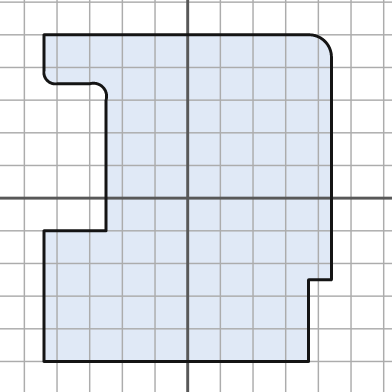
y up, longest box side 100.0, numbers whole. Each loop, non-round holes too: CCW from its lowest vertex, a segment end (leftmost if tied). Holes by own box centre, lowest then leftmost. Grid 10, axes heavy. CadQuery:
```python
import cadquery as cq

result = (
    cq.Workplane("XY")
    .moveTo(-44.0, -50.0)
    .lineTo(37.0, -50.0)
    .lineTo(37.0, -25.0)
    .lineTo(44.0, -25.0)
    .lineTo(44.0, 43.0)
    .threePointArc((42.0, 48.0), (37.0, 50.0))
    .lineTo(-44.0, 50.0)
    .lineTo(-44.0, 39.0)
    .threePointArc((-43.0, 36.0), (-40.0, 35.0))
    .lineTo(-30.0, 35.0)
    .threePointArc((-26.0, 34.0), (-25.0, 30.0))
    .lineTo(-25.0, -10.0)
    .lineTo(-44.0, -10.0)
    .close()
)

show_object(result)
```